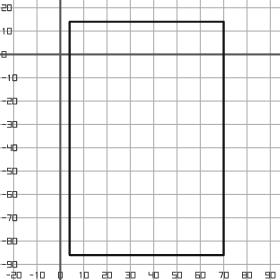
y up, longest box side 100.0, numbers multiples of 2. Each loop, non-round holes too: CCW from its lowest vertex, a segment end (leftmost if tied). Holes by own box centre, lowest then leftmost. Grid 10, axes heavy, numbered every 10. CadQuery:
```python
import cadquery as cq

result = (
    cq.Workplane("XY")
    .moveTo(4.0, -86.0)
    .lineTo(70.0, -86.0)
    .lineTo(70.0, 14.0)
    .lineTo(4.0, 14.0)
    .close()
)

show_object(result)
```